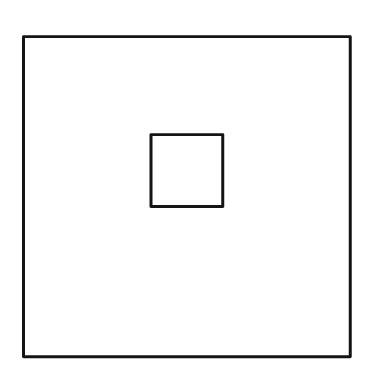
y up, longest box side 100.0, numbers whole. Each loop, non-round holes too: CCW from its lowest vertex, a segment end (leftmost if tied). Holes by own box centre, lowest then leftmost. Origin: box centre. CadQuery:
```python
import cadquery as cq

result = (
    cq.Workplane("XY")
    .moveTo(-50.0, -49.0)
    .lineTo(50.0, -49.0)
    .lineTo(50.0, 49.0)
    .lineTo(-50.0, 49.0)
    .close()
    .moveTo(-11.0, -3.0)
    .lineTo(11.0, -3.0)
    .lineTo(11.0, 19.0)
    .lineTo(-11.0, 19.0)
    .close()
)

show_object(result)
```